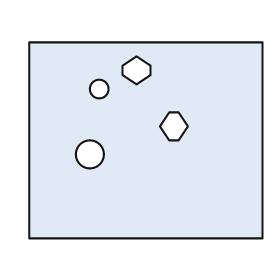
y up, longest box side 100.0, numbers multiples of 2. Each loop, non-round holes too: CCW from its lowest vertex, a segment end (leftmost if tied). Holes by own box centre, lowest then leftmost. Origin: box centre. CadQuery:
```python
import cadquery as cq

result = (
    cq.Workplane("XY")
    .moveTo(-50.0, -42.0)
    .lineTo(50.0, -42.0)
    .lineTo(50.0, 42.0)
    .lineTo(-50.0, 42.0)
    .close()
    .moveTo(-24.0, -6.0)
    .circle(6.0)
    .moveTo(10.0, 0.0)
    .lineTo(14.0, 0.0)
    .lineTo(18.0, 6.0)
    .lineTo(14.0, 12.0)
    .lineTo(10.0, 12.0)
    .lineTo(6.0, 6.0)
    .close()
    .moveTo(-20.0, 22.0)
    .circle(4.0)
    .moveTo(-4.0, 24.0)
    .lineTo(2.0, 28.0)
    .lineTo(2.0, 32.0)
    .lineTo(-4.0, 36.0)
    .lineTo(-10.0, 32.0)
    .lineTo(-10.0, 28.0)
    .close()
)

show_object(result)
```